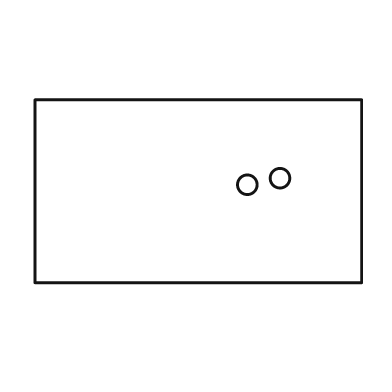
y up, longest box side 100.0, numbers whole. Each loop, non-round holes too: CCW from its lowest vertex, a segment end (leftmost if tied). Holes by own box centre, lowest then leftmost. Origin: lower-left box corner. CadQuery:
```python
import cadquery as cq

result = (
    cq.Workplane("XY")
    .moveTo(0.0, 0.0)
    .lineTo(100.0, 0.0)
    .lineTo(100.0, 56.0)
    .lineTo(0.0, 56.0)
    .close()
    .moveTo(65.0, 30.0)
    .circle(3.0)
    .moveTo(75.0, 32.0)
    .circle(3.0)
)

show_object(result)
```